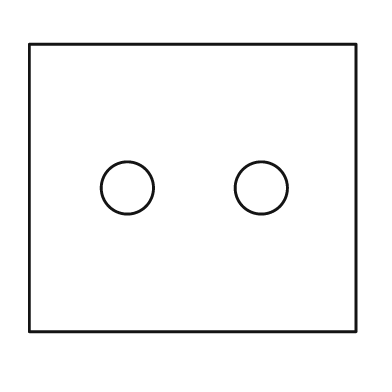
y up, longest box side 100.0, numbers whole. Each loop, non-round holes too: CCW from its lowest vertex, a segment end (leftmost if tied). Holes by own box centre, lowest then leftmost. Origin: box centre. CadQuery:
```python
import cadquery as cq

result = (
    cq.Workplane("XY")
    .moveTo(-50.0, -44.0)
    .lineTo(50.0, -44.0)
    .lineTo(50.0, 44.0)
    .lineTo(-50.0, 44.0)
    .close()
    .moveTo(-20.0, 0.0)
    .circle(8.0)
    .moveTo(21.0, 0.0)
    .circle(8.0)
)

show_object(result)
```